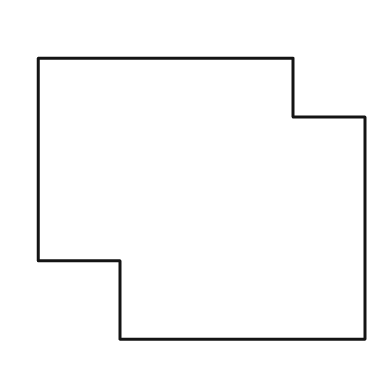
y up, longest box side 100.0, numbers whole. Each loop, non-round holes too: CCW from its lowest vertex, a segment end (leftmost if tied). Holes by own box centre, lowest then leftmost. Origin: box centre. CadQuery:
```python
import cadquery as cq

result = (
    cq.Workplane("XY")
    .moveTo(-25.0, -43.0)
    .lineTo(50.0, -43.0)
    .lineTo(50.0, 25.0)
    .lineTo(28.0, 25.0)
    .lineTo(28.0, 43.0)
    .lineTo(-50.0, 43.0)
    .lineTo(-50.0, -19.0)
    .lineTo(-25.0, -19.0)
    .close()
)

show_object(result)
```